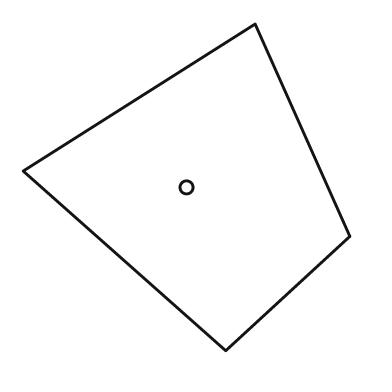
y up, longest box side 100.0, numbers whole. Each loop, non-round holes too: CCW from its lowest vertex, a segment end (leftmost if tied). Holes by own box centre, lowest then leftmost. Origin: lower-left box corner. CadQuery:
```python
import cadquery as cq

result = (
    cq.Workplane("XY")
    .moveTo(62.0, 0.0)
    .lineTo(100.0, 35.0)
    .lineTo(71.0, 100.0)
    .lineTo(0.0, 55.0)
    .close()
    .moveTo(50.0, 50.0)
    .circle(2.0)
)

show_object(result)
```